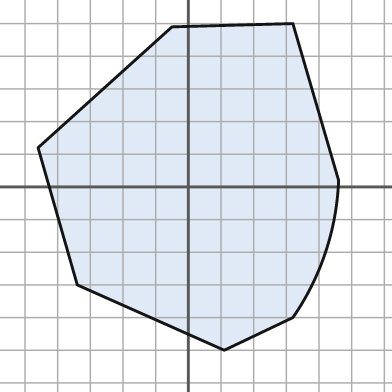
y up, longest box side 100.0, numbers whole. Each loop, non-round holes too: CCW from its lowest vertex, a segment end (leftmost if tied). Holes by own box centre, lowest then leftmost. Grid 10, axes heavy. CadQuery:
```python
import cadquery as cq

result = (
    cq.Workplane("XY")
    .moveTo(11.0, -50.0)
    .lineTo(32.0, -40.0)
    .threePointArc((42.0, -20.0), (46.0, 2.0))
    .lineTo(32.0, 50.0)
    .lineTo(-5.0, 49.0)
    .lineTo(-46.0, 12.0)
    .lineTo(-34.0, -30.0)
    .close()
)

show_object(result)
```